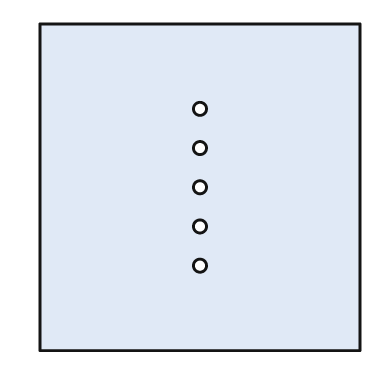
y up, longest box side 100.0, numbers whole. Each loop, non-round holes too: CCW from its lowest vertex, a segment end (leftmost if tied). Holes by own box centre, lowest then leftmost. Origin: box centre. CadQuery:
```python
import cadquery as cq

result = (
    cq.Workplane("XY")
    .moveTo(-49.0, -50.0)
    .lineTo(49.0, -50.0)
    .lineTo(49.0, 50.0)
    .lineTo(-49.0, 50.0)
    .close()
    .moveTo(0.0, -24.0)
    .circle(2.0)
    .moveTo(0.0, -12.0)
    .circle(2.0)
    .moveTo(0.0, 0.0)
    .circle(2.0)
    .moveTo(0.0, 12.0)
    .circle(2.0)
    .moveTo(0.0, 24.0)
    .circle(2.0)
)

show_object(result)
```